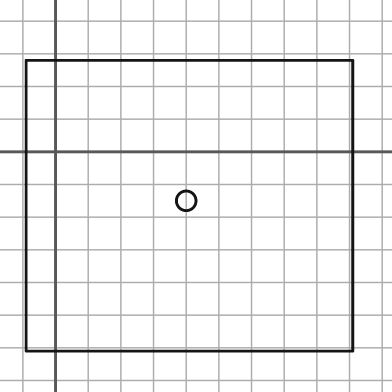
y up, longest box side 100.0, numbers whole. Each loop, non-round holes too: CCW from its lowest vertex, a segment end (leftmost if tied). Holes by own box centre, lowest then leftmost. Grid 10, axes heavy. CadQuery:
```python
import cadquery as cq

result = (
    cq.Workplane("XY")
    .moveTo(-9.0, -61.0)
    .lineTo(91.0, -61.0)
    .lineTo(91.0, 28.0)
    .lineTo(-9.0, 28.0)
    .close()
    .moveTo(40.0, -15.0)
    .circle(3.0)
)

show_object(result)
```